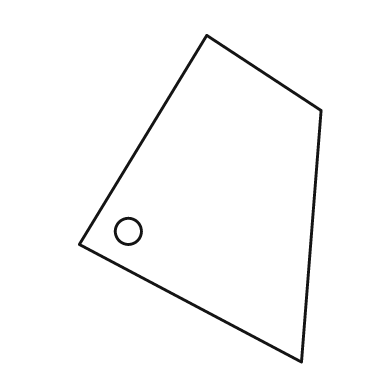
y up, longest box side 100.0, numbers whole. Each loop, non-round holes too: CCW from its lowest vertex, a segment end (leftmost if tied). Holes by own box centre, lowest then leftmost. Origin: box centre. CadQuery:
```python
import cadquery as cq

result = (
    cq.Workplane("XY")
    .moveTo(31.0, -50.0)
    .lineTo(37.0, 27.0)
    .lineTo(2.0, 50.0)
    .lineTo(-37.0, -14.0)
    .close()
    .moveTo(-22.0, -10.0)
    .circle(4.0)
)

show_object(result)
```